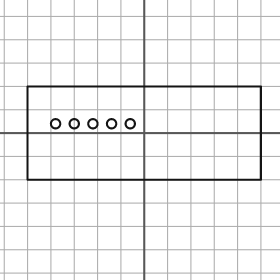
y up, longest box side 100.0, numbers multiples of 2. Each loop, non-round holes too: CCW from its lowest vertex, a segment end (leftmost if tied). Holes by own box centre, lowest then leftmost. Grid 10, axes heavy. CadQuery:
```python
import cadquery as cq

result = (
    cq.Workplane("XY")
    .moveTo(-50.0, -20.0)
    .lineTo(50.0, -20.0)
    .lineTo(50.0, 20.0)
    .lineTo(-50.0, 20.0)
    .close()
    .moveTo(-38.0, 4.0)
    .circle(2.0)
    .moveTo(-30.0, 4.0)
    .circle(2.0)
    .moveTo(-22.0, 4.0)
    .circle(2.0)
    .moveTo(-14.0, 4.0)
    .circle(2.0)
    .moveTo(-6.0, 4.0)
    .circle(2.0)
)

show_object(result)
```